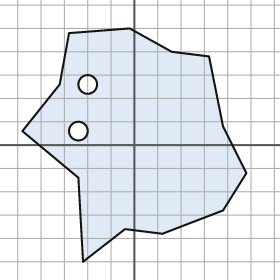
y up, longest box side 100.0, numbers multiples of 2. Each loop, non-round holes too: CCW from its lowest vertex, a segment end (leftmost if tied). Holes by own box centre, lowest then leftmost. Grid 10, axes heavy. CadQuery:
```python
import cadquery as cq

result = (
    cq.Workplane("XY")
    .moveTo(-22.0, -50.0)
    .lineTo(-4.0, -36.0)
    .lineTo(12.0, -38.0)
    .lineTo(38.0, -28.0)
    .lineTo(48.0, -12.0)
    .lineTo(38.0, 8.0)
    .lineTo(32.0, 38.0)
    .lineTo(16.0, 40.0)
    .lineTo(-2.0, 50.0)
    .lineTo(-28.0, 48.0)
    .lineTo(-32.0, 26.0)
    .lineTo(-48.0, 6.0)
    .lineTo(-24.0, -14.0)
    .close()
    .moveTo(-24.0, 6.0)
    .circle(4.0)
    .moveTo(-20.0, 26.0)
    .circle(4.0)
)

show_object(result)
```